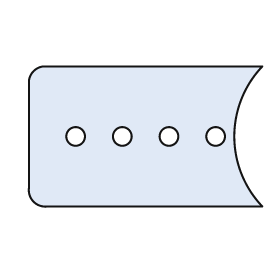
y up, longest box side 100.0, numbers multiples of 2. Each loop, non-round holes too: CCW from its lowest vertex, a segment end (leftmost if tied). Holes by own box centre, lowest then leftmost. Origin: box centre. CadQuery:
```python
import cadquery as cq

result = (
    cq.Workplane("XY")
    .moveTo(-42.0, -30.0)
    .lineTo(50.0, -30.0)
    .threePointArc((38.0, 0.0), (50.0, 30.0))
    .lineTo(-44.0, 30.0)
    .threePointArc((-48.0, 28.0), (-50.0, 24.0))
    .lineTo(-50.0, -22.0)
    .threePointArc((-48.0, -28.0), (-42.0, -30.0))
    .close()
    .moveTo(-30.0, 0.0)
    .circle(4.0)
    .moveTo(-10.0, 0.0)
    .circle(4.0)
    .moveTo(10.0, 0.0)
    .circle(4.0)
    .moveTo(30.0, 0.0)
    .circle(4.0)
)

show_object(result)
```